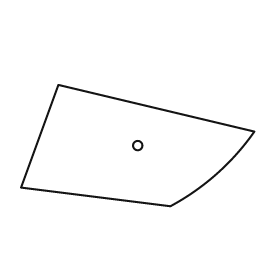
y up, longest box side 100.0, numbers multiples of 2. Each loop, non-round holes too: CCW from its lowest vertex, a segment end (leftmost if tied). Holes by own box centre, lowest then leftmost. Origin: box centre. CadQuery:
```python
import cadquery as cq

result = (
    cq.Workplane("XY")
    .moveTo(14.0, -26.0)
    .threePointArc((34.0, -12.0), (50.0, 6.0))
    .lineTo(-34.0, 26.0)
    .lineTo(-50.0, -18.0)
    .close()
    .moveTo(0.0, 0.0)
    .circle(2.0)
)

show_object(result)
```